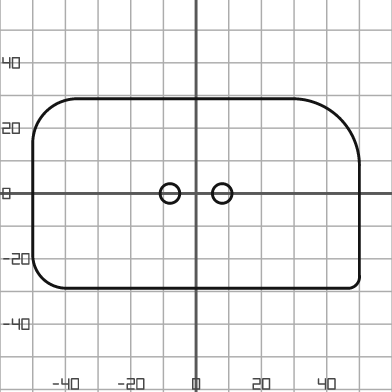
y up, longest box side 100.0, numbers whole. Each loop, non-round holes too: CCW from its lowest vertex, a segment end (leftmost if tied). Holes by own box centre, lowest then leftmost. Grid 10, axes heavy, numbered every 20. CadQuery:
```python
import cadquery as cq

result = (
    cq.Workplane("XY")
    .moveTo(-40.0, -29.0)
    .lineTo(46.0, -29.0)
    .threePointArc((49.0, -28.0), (50.0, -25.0))
    .lineTo(50.0, 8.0)
    .threePointArc((44.0, 23.0), (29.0, 29.0))
    .lineTo(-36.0, 29.0)
    .threePointArc((-46.0, 25.0), (-50.0, 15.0))
    .lineTo(-50.0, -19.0)
    .threePointArc((-47.0, -26.0), (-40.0, -29.0))
    .close()
    .moveTo(-8.0, 0.0)
    .circle(3.0)
    .moveTo(8.0, 0.0)
    .circle(3.0)
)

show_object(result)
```